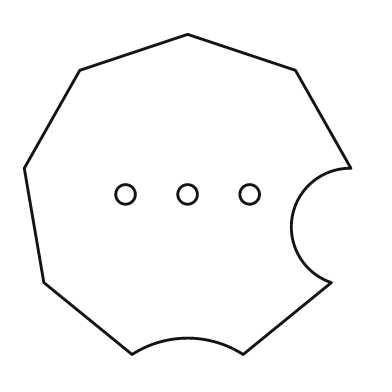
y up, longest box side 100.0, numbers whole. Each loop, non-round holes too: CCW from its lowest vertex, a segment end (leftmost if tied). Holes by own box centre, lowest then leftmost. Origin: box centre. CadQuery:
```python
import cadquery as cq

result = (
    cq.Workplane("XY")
    .moveTo(-17.0, -49.0)
    .threePointArc((0.0, -44.0), (17.0, -49.0))
    .lineTo(44.0, -27.0)
    .threePointArc((32.0, -7.0), (50.0, 8.0))
    .lineTo(33.0, 38.0)
    .lineTo(0.0, 49.0)
    .lineTo(-33.0, 38.0)
    .lineTo(-50.0, 8.0)
    .lineTo(-44.0, -27.0)
    .close()
    .moveTo(-19.0, 0.0)
    .circle(3.0)
    .moveTo(0.0, 0.0)
    .circle(3.0)
    .moveTo(19.0, 0.0)
    .circle(3.0)
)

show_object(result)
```